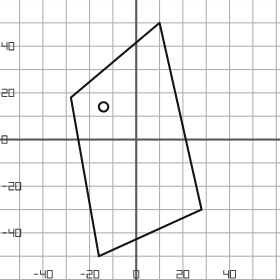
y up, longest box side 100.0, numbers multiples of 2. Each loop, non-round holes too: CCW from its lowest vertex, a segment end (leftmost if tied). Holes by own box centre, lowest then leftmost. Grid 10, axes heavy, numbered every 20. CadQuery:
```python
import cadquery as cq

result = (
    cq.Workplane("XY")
    .moveTo(-16.0, -50.0)
    .lineTo(28.0, -30.0)
    .lineTo(10.0, 50.0)
    .lineTo(-28.0, 18.0)
    .close()
    .moveTo(-14.0, 14.0)
    .circle(2.0)
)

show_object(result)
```